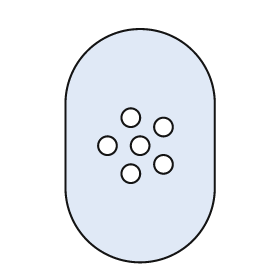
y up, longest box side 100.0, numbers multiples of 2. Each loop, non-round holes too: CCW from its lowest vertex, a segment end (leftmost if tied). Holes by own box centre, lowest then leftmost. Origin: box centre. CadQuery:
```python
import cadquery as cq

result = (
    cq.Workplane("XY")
    .moveTo(-32.0, -18.0)
    .threePointArc((0.0, -50.0), (32.0, -18.0))
    .lineTo(32.0, 18.0)
    .threePointArc((0.0, 50.0), (-32.0, 18.0))
    .close()
    .moveTo(-4.0, -12.0)
    .circle(4.0)
    .moveTo(10.0, -8.0)
    .circle(4.0)
    .moveTo(-14.0, 0.0)
    .circle(4.0)
    .moveTo(0.0, 0.0)
    .circle(4.0)
    .moveTo(10.0, 8.0)
    .circle(4.0)
    .moveTo(-4.0, 12.0)
    .circle(4.0)
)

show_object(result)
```